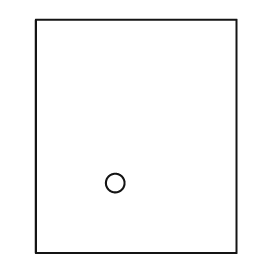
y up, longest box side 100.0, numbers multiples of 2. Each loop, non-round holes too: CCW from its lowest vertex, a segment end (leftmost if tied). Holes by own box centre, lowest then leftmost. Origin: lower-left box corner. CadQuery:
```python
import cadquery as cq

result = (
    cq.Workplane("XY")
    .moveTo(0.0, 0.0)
    .lineTo(86.0, 0.0)
    .lineTo(86.0, 100.0)
    .lineTo(0.0, 100.0)
    .close()
    .moveTo(34.0, 30.0)
    .circle(4.0)
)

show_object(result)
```